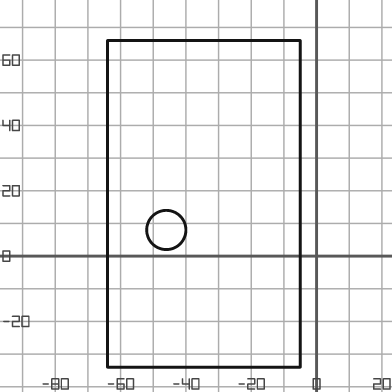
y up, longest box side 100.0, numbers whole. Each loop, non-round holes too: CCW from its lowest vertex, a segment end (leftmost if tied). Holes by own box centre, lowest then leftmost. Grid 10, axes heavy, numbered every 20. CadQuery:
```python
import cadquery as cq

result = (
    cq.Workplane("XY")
    .moveTo(-64.0, -34.0)
    .lineTo(-5.0, -34.0)
    .lineTo(-5.0, 66.0)
    .lineTo(-64.0, 66.0)
    .close()
    .moveTo(-46.0, 8.0)
    .circle(6.0)
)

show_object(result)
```